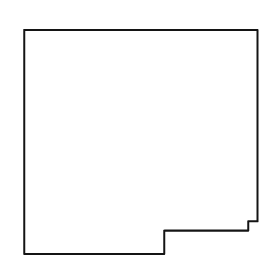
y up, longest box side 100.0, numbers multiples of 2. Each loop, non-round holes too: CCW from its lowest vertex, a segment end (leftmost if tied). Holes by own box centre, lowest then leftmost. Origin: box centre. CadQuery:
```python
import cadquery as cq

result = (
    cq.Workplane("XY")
    .moveTo(-50.0, -48.0)
    .lineTo(10.0, -48.0)
    .lineTo(10.0, -38.0)
    .lineTo(46.0, -38.0)
    .lineTo(46.0, -34.0)
    .lineTo(50.0, -34.0)
    .lineTo(50.0, 48.0)
    .lineTo(-50.0, 48.0)
    .close()
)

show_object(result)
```